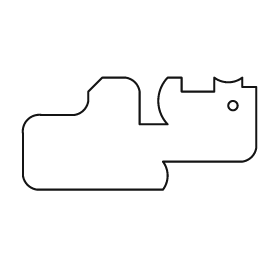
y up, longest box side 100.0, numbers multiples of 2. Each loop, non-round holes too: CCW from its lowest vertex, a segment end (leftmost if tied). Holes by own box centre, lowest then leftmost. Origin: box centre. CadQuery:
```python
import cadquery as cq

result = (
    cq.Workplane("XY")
    .moveTo(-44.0, -24.0)
    .lineTo(10.0, -24.0)
    .threePointArc((12.0, -18.0), (10.0, -12.0))
    .lineTo(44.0, -12.0)
    .threePointArc((48.0, -10.0), (50.0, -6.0))
    .lineTo(50.0, 20.0)
    .lineTo(44.0, 20.0)
    .lineTo(44.0, 24.0)
    .threePointArc((38.0, 22.0), (32.0, 24.0))
    .lineTo(32.0, 18.0)
    .lineTo(18.0, 18.0)
    .lineTo(18.0, 24.0)
    .lineTo(12.0, 24.0)
    .threePointArc((8.0, 14.0), (12.0, 4.0))
    .lineTo(0.0, 4.0)
    .lineTo(0.0, 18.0)
    .threePointArc((-2.0, 22.0), (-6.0, 24.0))
    .lineTo(-16.0, 24.0)
    .lineTo(-22.0, 18.0)
    .lineTo(-22.0, 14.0)
    .threePointArc((-24.0, 10.0), (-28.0, 8.0))
    .lineTo(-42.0, 8.0)
    .threePointArc((-48.0, 6.0), (-50.0, 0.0))
    .lineTo(-50.0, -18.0)
    .threePointArc((-48.0, -22.0), (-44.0, -24.0))
    .close()
    .moveTo(40.0, 12.0)
    .circle(2.0)
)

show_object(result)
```